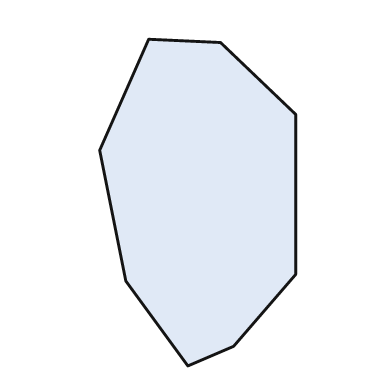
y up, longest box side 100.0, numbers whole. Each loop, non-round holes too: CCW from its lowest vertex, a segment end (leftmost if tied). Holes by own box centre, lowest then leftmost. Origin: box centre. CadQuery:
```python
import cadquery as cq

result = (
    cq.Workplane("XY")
    .moveTo(-3.0, -50.0)
    .lineTo(11.0, -44.0)
    .lineTo(30.0, -22.0)
    .lineTo(30.0, 27.0)
    .lineTo(7.0, 49.0)
    .lineTo(-15.0, 50.0)
    .lineTo(-30.0, 16.0)
    .lineTo(-22.0, -24.0)
    .close()
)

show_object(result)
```